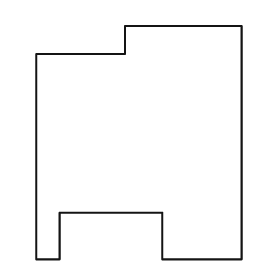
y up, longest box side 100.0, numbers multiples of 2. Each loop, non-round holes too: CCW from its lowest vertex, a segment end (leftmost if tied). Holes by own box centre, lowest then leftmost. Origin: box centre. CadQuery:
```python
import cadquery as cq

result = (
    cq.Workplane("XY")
    .moveTo(-44.0, -50.0)
    .lineTo(-34.0, -50.0)
    .lineTo(-34.0, -30.0)
    .lineTo(10.0, -30.0)
    .lineTo(10.0, -50.0)
    .lineTo(44.0, -50.0)
    .lineTo(44.0, 50.0)
    .lineTo(-6.0, 50.0)
    .lineTo(-6.0, 38.0)
    .lineTo(-44.0, 38.0)
    .close()
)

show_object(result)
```